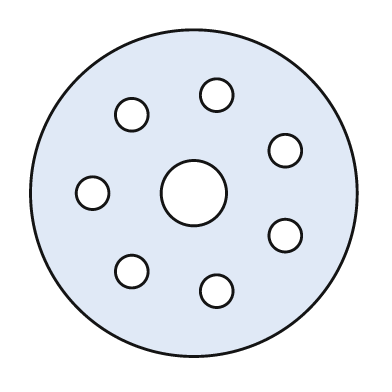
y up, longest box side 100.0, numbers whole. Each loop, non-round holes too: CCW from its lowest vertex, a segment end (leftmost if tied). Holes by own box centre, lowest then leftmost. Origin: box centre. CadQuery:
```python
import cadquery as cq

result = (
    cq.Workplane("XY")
    .moveTo(0.0, 0.0)
    .circle(50.0)
    .moveTo(7.0, -30.0)
    .circle(5.0)
    .moveTo(-19.0, -24.0)
    .circle(5.0)
    .moveTo(28.0, -13.0)
    .circle(5.0)
    .moveTo(-31.0, 0.0)
    .circle(5.0)
    .moveTo(0.0, 0.0)
    .circle(10.0)
    .moveTo(28.0, 13.0)
    .circle(5.0)
    .moveTo(-19.0, 24.0)
    .circle(5.0)
    .moveTo(7.0, 30.0)
    .circle(5.0)
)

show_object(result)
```